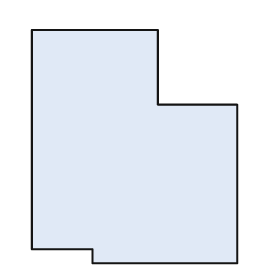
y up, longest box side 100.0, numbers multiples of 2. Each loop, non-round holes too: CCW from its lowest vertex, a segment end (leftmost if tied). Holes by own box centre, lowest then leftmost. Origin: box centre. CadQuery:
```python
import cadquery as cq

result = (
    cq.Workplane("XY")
    .moveTo(-18.0, -50.0)
    .lineTo(44.0, -50.0)
    .lineTo(44.0, 18.0)
    .lineTo(10.0, 18.0)
    .lineTo(10.0, 50.0)
    .lineTo(-44.0, 50.0)
    .lineTo(-44.0, -44.0)
    .lineTo(-18.0, -44.0)
    .close()
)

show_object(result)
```